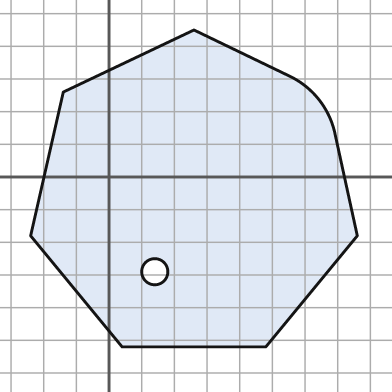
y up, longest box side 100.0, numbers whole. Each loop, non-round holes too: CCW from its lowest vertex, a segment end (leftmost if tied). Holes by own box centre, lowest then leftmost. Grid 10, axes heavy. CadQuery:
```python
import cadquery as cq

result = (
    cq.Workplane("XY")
    .moveTo(4.0, -52.0)
    .lineTo(48.0, -52.0)
    .lineTo(76.0, -18.0)
    .lineTo(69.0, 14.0)
    .threePointArc((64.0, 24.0), (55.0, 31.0))
    .lineTo(26.0, 45.0)
    .lineTo(-14.0, 26.0)
    .lineTo(-24.0, -18.0)
    .close()
    .moveTo(14.0, -29.0)
    .circle(4.0)
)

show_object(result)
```